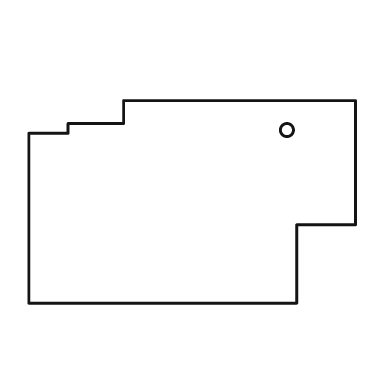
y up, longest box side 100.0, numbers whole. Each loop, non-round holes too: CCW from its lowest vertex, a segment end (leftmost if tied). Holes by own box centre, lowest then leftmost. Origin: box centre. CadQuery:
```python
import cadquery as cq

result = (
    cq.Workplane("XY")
    .moveTo(-50.0, -31.0)
    .lineTo(32.0, -31.0)
    .lineTo(32.0, -7.0)
    .lineTo(50.0, -7.0)
    .lineTo(50.0, 31.0)
    .lineTo(-21.0, 31.0)
    .lineTo(-21.0, 24.0)
    .lineTo(-38.0, 24.0)
    .lineTo(-38.0, 21.0)
    .lineTo(-50.0, 21.0)
    .close()
    .moveTo(29.0, 22.0)
    .circle(2.0)
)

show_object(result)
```